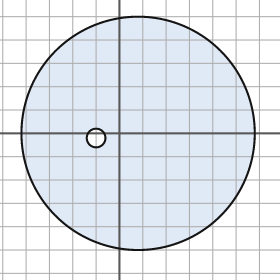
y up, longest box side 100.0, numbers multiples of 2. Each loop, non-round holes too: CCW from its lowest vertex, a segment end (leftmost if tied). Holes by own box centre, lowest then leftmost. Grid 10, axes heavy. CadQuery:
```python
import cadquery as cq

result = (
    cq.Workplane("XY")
    .moveTo(8.0, 0.0)
    .circle(50.0)
    .moveTo(-10.0, -2.0)
    .circle(4.0)
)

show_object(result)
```